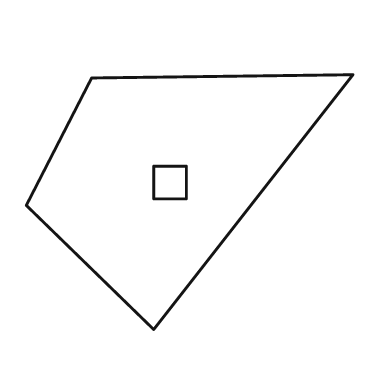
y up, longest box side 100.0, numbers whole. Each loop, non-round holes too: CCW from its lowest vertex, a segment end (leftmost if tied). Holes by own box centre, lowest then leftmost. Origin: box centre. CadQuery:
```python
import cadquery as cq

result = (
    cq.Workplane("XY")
    .moveTo(-11.0, -39.0)
    .lineTo(50.0, 39.0)
    .lineTo(-30.0, 38.0)
    .lineTo(-50.0, -1.0)
    .close()
    .moveTo(-11.0, 1.0)
    .lineTo(-1.0, 1.0)
    .lineTo(-1.0, 11.0)
    .lineTo(-11.0, 11.0)
    .close()
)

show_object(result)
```